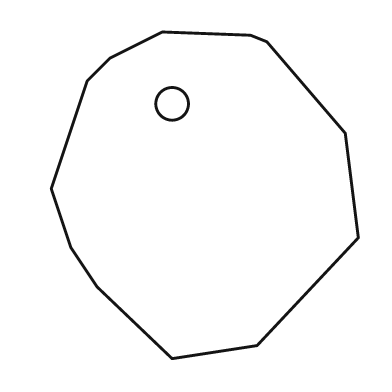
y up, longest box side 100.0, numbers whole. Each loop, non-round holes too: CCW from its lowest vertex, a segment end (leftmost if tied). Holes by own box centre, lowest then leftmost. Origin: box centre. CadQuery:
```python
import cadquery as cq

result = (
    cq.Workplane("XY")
    .moveTo(-10.0, -50.0)
    .lineTo(16.0, -46.0)
    .lineTo(47.0, -13.0)
    .lineTo(43.0, 19.0)
    .lineTo(19.0, 47.0)
    .lineTo(14.0, 49.0)
    .lineTo(-13.0, 50.0)
    .lineTo(-29.0, 42.0)
    .lineTo(-36.0, 35.0)
    .lineTo(-47.0, 2.0)
    .lineTo(-41.0, -16.0)
    .lineTo(-33.0, -28.0)
    .close()
    .moveTo(-10.0, 28.0)
    .circle(5.0)
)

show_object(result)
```